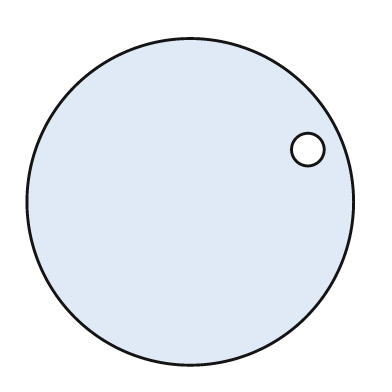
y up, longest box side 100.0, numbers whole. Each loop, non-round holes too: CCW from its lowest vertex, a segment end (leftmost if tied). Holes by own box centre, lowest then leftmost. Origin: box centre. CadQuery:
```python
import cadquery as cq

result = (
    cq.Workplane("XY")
    .moveTo(0.0, 0.0)
    .circle(50.0)
    .moveTo(36.0, 16.0)
    .circle(5.0)
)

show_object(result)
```